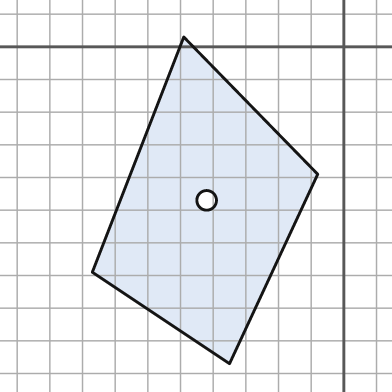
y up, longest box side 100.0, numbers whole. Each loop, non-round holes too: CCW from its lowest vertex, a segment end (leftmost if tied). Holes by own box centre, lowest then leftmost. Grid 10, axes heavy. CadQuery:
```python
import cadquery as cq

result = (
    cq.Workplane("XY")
    .moveTo(-35.0, -97.0)
    .lineTo(-8.0, -39.0)
    .lineTo(-49.0, 3.0)
    .lineTo(-77.0, -69.0)
    .close()
    .moveTo(-42.0, -47.0)
    .circle(3.0)
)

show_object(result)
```